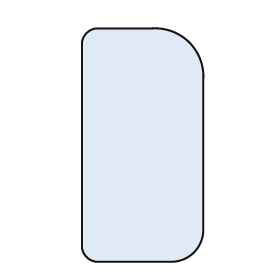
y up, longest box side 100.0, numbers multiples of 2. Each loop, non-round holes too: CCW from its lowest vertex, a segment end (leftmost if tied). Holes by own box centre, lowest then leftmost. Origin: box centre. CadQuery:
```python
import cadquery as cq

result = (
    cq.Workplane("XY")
    .moveTo(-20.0, -50.0)
    .lineTo(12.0, -50.0)
    .threePointArc((22.0, -46.0), (26.0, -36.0))
    .lineTo(26.0, 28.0)
    .threePointArc((20.0, 44.0), (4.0, 50.0))
    .lineTo(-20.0, 50.0)
    .threePointArc((-24.0, 48.0), (-26.0, 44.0))
    .lineTo(-26.0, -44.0)
    .threePointArc((-24.0, -48.0), (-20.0, -50.0))
    .close()
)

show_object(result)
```